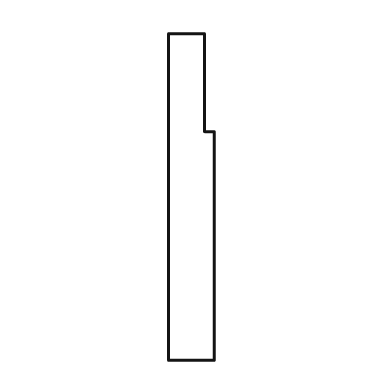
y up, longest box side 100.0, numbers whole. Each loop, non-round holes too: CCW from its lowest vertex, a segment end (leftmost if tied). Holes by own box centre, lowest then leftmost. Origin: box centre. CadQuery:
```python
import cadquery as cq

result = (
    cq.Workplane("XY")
    .moveTo(-7.0, -50.0)
    .lineTo(7.0, -50.0)
    .lineTo(7.0, 20.0)
    .lineTo(4.0, 20.0)
    .lineTo(4.0, 50.0)
    .lineTo(-7.0, 50.0)
    .close()
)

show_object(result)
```